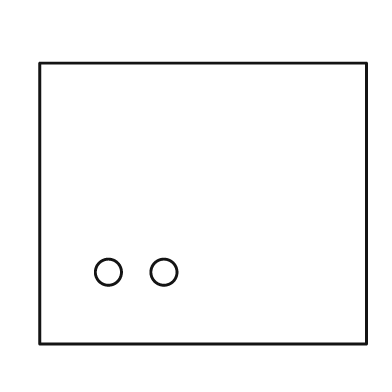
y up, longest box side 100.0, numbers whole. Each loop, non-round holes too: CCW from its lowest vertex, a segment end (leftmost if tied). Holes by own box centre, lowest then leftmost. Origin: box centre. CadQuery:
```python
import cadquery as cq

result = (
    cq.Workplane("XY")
    .moveTo(-50.0, -43.0)
    .lineTo(50.0, -43.0)
    .lineTo(50.0, 43.0)
    .lineTo(-50.0, 43.0)
    .close()
    .moveTo(-29.0, -21.0)
    .circle(4.0)
    .moveTo(-12.0, -21.0)
    .circle(4.0)
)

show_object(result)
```